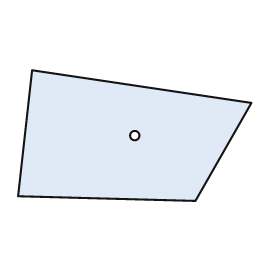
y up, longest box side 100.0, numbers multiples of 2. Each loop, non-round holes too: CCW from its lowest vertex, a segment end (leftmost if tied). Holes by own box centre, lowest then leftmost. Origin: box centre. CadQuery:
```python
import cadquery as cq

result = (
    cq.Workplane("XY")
    .moveTo(26.0, -28.0)
    .lineTo(50.0, 14.0)
    .lineTo(-44.0, 28.0)
    .lineTo(-50.0, -26.0)
    .close()
    .moveTo(0.0, 0.0)
    .circle(2.0)
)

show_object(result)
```